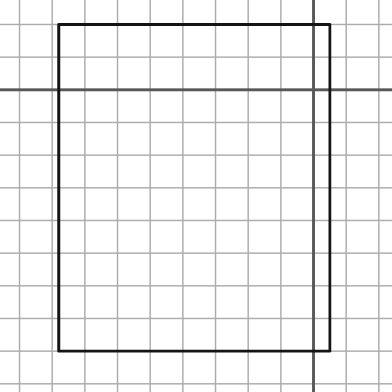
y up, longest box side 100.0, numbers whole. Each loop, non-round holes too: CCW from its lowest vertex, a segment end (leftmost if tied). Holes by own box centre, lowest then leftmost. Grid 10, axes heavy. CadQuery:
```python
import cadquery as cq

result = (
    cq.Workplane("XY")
    .moveTo(-78.0, -80.0)
    .lineTo(5.0, -80.0)
    .lineTo(5.0, 20.0)
    .lineTo(-78.0, 20.0)
    .close()
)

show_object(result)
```